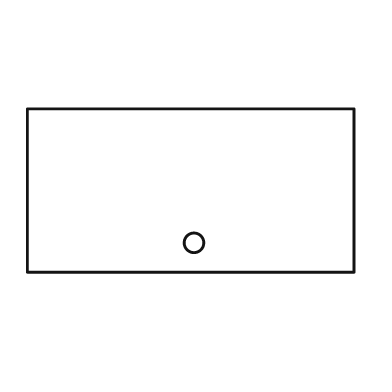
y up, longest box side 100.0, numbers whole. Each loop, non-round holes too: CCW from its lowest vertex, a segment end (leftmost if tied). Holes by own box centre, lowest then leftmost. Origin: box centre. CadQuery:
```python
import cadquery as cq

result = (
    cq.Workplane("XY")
    .moveTo(-50.0, -25.0)
    .lineTo(50.0, -25.0)
    .lineTo(50.0, 25.0)
    .lineTo(-50.0, 25.0)
    .close()
    .moveTo(1.0, -16.0)
    .circle(3.0)
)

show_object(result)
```